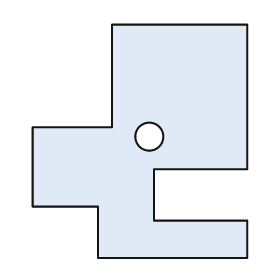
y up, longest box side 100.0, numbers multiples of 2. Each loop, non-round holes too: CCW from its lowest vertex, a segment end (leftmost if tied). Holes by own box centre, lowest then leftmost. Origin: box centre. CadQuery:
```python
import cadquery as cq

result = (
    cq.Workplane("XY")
    .moveTo(-18.0, -50.0)
    .lineTo(46.0, -50.0)
    .lineTo(46.0, -34.0)
    .lineTo(6.0, -34.0)
    .lineTo(6.0, -12.0)
    .lineTo(46.0, -12.0)
    .lineTo(46.0, 50.0)
    .lineTo(-12.0, 50.0)
    .lineTo(-12.0, 6.0)
    .lineTo(-46.0, 6.0)
    .lineTo(-46.0, -28.0)
    .lineTo(-18.0, -28.0)
    .close()
    .moveTo(4.0, 2.0)
    .circle(6.0)
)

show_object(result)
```